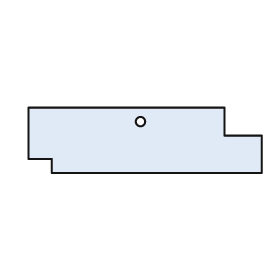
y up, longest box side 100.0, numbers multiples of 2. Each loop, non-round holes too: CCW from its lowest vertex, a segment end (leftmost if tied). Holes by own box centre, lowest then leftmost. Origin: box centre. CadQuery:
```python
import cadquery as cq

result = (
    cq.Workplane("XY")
    .moveTo(-40.0, -14.0)
    .lineTo(50.0, -14.0)
    .lineTo(50.0, 2.0)
    .lineTo(34.0, 2.0)
    .lineTo(34.0, 14.0)
    .lineTo(-50.0, 14.0)
    .lineTo(-50.0, -8.0)
    .lineTo(-40.0, -8.0)
    .close()
    .moveTo(-2.0, 8.0)
    .circle(2.0)
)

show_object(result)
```